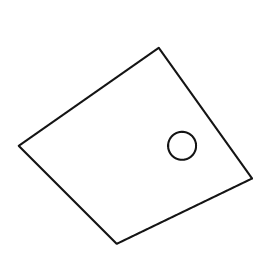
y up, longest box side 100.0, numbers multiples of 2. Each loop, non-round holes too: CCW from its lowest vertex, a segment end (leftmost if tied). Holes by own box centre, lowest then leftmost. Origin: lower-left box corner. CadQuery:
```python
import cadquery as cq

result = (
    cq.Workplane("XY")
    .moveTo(42.0, 0.0)
    .lineTo(100.0, 28.0)
    .lineTo(60.0, 84.0)
    .lineTo(0.0, 42.0)
    .close()
    .moveTo(70.0, 42.0)
    .circle(6.0)
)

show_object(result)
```